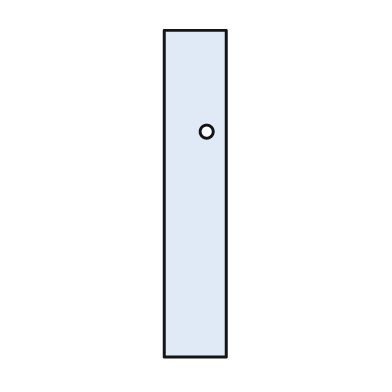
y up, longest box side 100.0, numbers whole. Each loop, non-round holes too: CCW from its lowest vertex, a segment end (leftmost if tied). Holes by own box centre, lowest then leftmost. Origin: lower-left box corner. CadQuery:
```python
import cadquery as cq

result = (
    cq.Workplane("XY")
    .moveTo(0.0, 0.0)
    .lineTo(19.0, 0.0)
    .lineTo(19.0, 100.0)
    .lineTo(0.0, 100.0)
    .close()
    .moveTo(13.0, 69.0)
    .circle(2.0)
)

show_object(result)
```